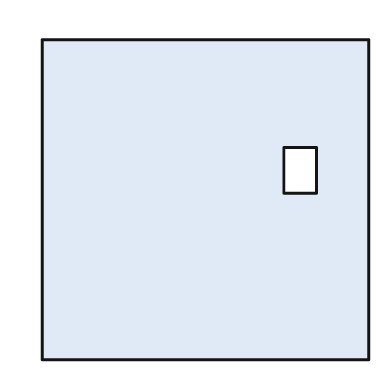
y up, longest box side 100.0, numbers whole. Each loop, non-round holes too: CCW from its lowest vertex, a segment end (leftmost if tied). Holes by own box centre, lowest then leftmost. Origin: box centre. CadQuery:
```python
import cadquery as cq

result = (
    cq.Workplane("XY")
    .moveTo(-50.0, -49.0)
    .lineTo(50.0, -49.0)
    .lineTo(50.0, 49.0)
    .lineTo(-50.0, 49.0)
    .close()
    .moveTo(24.0, 2.0)
    .lineTo(34.0, 2.0)
    .lineTo(34.0, 16.0)
    .lineTo(24.0, 16.0)
    .close()
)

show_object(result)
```